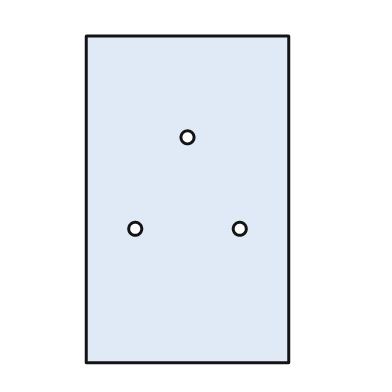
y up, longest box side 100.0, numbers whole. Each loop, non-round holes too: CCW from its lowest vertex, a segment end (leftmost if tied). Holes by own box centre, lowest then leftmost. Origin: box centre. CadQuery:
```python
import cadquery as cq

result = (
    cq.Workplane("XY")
    .moveTo(-31.0, -50.0)
    .lineTo(31.0, -50.0)
    .lineTo(31.0, 50.0)
    .lineTo(-31.0, 50.0)
    .close()
    .moveTo(-16.0, -9.0)
    .circle(2.0)
    .moveTo(16.0, -9.0)
    .circle(2.0)
    .moveTo(0.0, 19.0)
    .circle(2.0)
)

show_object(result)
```